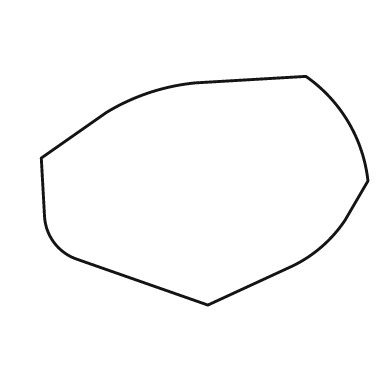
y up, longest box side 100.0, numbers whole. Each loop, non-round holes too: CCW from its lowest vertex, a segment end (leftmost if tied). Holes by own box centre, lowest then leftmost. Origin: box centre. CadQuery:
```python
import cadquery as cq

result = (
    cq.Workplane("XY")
    .moveTo(1.0, -35.0)
    .lineTo(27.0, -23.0)
    .threePointArc((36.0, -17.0), (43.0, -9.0))
    .lineTo(50.0, 3.0)
    .threePointArc((44.0, 21.0), (31.0, 35.0))
    .lineTo(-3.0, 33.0)
    .threePointArc((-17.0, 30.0), (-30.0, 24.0))
    .lineTo(-50.0, 10.0)
    .lineTo(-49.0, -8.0)
    .threePointArc((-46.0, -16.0), (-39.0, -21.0))
    .close()
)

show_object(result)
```